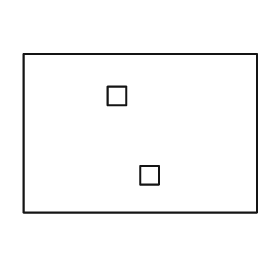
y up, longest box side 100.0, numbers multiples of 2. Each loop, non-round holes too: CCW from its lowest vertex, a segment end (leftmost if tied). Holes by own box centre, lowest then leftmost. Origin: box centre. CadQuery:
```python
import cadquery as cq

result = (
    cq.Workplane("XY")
    .moveTo(-50.0, -34.0)
    .lineTo(50.0, -34.0)
    .lineTo(50.0, 34.0)
    .lineTo(-50.0, 34.0)
    .close()
    .moveTo(0.0, -22.0)
    .lineTo(8.0, -22.0)
    .lineTo(8.0, -14.0)
    .lineTo(0.0, -14.0)
    .close()
    .moveTo(-14.0, 12.0)
    .lineTo(-6.0, 12.0)
    .lineTo(-6.0, 20.0)
    .lineTo(-14.0, 20.0)
    .close()
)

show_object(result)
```